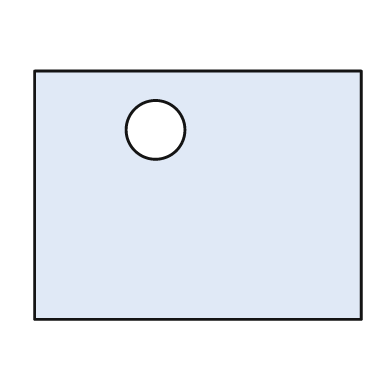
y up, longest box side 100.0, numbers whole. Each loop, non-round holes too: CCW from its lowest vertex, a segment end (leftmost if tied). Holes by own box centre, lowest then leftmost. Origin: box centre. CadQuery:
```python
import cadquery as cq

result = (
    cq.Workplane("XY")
    .moveTo(-50.0, -38.0)
    .lineTo(50.0, -38.0)
    .lineTo(50.0, 38.0)
    .lineTo(-50.0, 38.0)
    .close()
    .moveTo(-13.0, 20.0)
    .circle(9.0)
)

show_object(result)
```